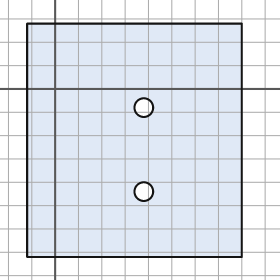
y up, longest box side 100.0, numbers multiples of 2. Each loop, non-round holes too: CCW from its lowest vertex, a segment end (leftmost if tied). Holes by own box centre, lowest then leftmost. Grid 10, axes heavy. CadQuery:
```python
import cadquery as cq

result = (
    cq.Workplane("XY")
    .moveTo(-12.0, -72.0)
    .lineTo(80.0, -72.0)
    .lineTo(80.0, 28.0)
    .lineTo(-12.0, 28.0)
    .close()
    .moveTo(38.0, -44.0)
    .circle(4.0)
    .moveTo(38.0, -8.0)
    .circle(4.0)
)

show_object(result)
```